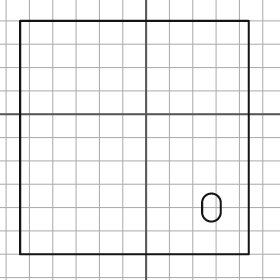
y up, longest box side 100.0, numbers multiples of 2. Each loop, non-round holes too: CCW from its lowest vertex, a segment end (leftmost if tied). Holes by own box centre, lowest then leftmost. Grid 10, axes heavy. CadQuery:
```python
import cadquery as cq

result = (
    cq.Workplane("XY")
    .moveTo(-54.0, -60.0)
    .lineTo(44.0, -60.0)
    .lineTo(44.0, 40.0)
    .lineTo(-54.0, 40.0)
    .close()
    .moveTo(24.0, -42.0)
    .threePointArc((28.0, -46.0), (32.0, -42.0))
    .lineTo(32.0, -38.0)
    .threePointArc((28.0, -34.0), (24.0, -38.0))
    .close()
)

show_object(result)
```